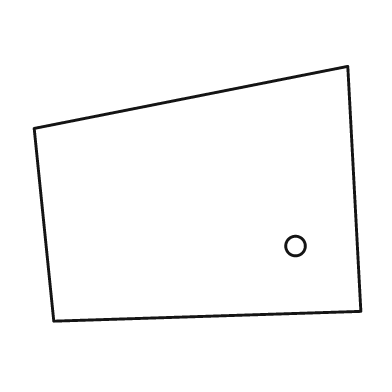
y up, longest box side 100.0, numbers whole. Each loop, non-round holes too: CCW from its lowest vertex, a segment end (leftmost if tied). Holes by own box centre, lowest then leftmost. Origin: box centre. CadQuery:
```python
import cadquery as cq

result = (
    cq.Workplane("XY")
    .moveTo(-44.0, -39.0)
    .lineTo(50.0, -36.0)
    .lineTo(46.0, 39.0)
    .lineTo(-50.0, 20.0)
    .close()
    .moveTo(30.0, -16.0)
    .circle(3.0)
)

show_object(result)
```